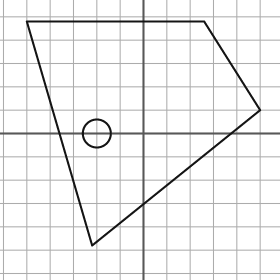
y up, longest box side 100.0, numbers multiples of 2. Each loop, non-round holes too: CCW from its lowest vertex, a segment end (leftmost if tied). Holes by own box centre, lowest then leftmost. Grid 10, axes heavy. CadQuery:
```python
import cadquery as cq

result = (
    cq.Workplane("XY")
    .moveTo(-22.0, -48.0)
    .lineTo(50.0, 10.0)
    .lineTo(26.0, 48.0)
    .lineTo(-50.0, 48.0)
    .close()
    .moveTo(-20.0, 0.0)
    .circle(6.0)
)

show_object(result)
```